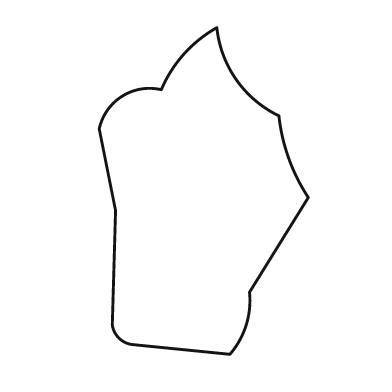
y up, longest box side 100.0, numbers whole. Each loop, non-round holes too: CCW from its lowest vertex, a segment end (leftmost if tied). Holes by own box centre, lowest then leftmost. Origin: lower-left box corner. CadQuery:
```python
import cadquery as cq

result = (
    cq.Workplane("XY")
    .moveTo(40.0, 0.0)
    .threePointArc((45.0, 9.0), (46.0, 19.0))
    .lineTo(64.0, 48.0)
    .threePointArc((58.0, 60.0), (55.0, 73.0))
    .threePointArc((42.0, 84.0), (36.0, 100.0))
    .threePointArc((26.0, 92.0), (19.0, 81.0))
    .threePointArc((7.0, 79.0), (0.0, 69.0))
    .lineTo(5.0, 44.0)
    .lineTo(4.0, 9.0)
    .threePointArc((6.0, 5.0), (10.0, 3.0))
    .close()
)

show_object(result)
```